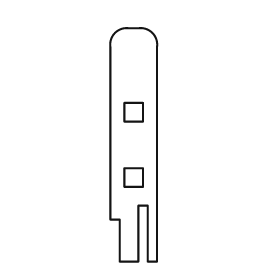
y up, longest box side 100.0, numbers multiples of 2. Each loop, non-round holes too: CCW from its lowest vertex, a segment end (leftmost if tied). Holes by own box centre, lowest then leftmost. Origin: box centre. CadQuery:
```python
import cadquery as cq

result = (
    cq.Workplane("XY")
    .moveTo(-6.0, -50.0)
    .lineTo(2.0, -50.0)
    .lineTo(2.0, -26.0)
    .lineTo(6.0, -26.0)
    .lineTo(6.0, -50.0)
    .lineTo(10.0, -50.0)
    .lineTo(10.0, 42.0)
    .threePointArc((8.0, 48.0), (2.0, 50.0))
    .lineTo(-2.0, 50.0)
    .threePointArc((-8.0, 48.0), (-10.0, 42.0))
    .lineTo(-10.0, -32.0)
    .lineTo(-6.0, -32.0)
    .close()
    .moveTo(-4.0, -18.0)
    .lineTo(4.0, -18.0)
    .lineTo(4.0, -10.0)
    .lineTo(-4.0, -10.0)
    .close()
    .moveTo(-4.0, 10.0)
    .lineTo(4.0, 10.0)
    .lineTo(4.0, 18.0)
    .lineTo(-4.0, 18.0)
    .close()
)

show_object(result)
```